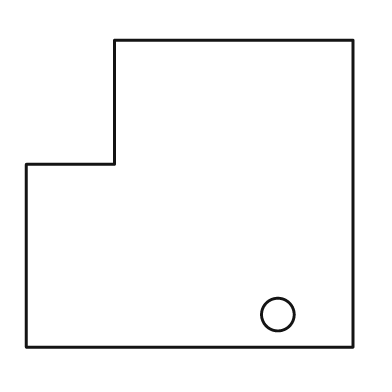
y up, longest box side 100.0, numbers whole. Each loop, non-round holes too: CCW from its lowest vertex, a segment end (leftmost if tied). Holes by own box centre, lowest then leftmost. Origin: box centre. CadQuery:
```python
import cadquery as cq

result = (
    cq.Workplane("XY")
    .moveTo(-50.0, -47.0)
    .lineTo(50.0, -47.0)
    .lineTo(50.0, 47.0)
    .lineTo(-23.0, 47.0)
    .lineTo(-23.0, 9.0)
    .lineTo(-50.0, 9.0)
    .close()
    .moveTo(27.0, -37.0)
    .circle(5.0)
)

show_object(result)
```